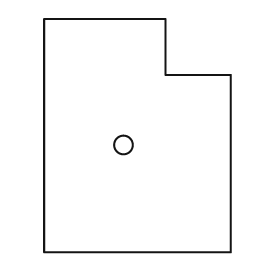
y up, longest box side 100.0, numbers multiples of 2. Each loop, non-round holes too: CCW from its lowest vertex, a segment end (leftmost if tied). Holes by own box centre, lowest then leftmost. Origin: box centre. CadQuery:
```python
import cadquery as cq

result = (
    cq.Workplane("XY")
    .moveTo(-40.0, -50.0)
    .lineTo(40.0, -50.0)
    .lineTo(40.0, 26.0)
    .lineTo(12.0, 26.0)
    .lineTo(12.0, 50.0)
    .lineTo(-40.0, 50.0)
    .close()
    .moveTo(-6.0, -4.0)
    .circle(4.0)
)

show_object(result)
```